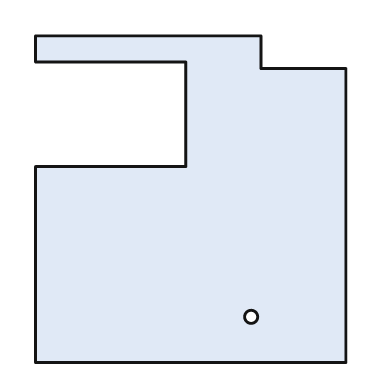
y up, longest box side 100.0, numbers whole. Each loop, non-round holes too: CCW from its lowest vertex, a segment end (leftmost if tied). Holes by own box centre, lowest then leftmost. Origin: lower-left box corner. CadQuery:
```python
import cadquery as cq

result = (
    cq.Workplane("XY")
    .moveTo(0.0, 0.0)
    .lineTo(95.0, 0.0)
    .lineTo(95.0, 90.0)
    .lineTo(69.0, 90.0)
    .lineTo(69.0, 100.0)
    .lineTo(0.0, 100.0)
    .lineTo(0.0, 92.0)
    .lineTo(46.0, 92.0)
    .lineTo(46.0, 60.0)
    .lineTo(0.0, 60.0)
    .close()
    .moveTo(66.0, 14.0)
    .circle(2.0)
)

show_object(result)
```